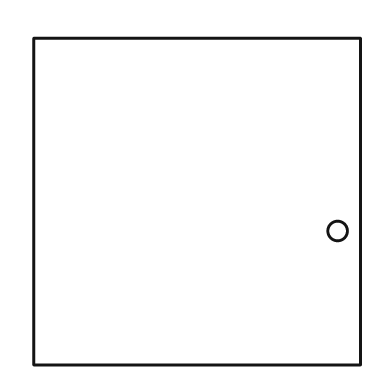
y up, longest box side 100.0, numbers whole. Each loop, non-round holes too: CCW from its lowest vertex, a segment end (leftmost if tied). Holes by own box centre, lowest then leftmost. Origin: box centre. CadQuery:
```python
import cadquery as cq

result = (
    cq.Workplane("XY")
    .moveTo(-50.0, -50.0)
    .lineTo(50.0, -50.0)
    .lineTo(50.0, 50.0)
    .lineTo(-50.0, 50.0)
    .close()
    .moveTo(43.0, -9.0)
    .circle(3.0)
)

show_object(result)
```